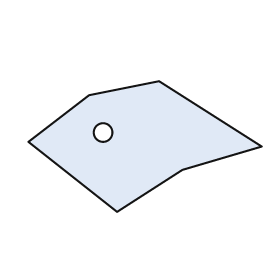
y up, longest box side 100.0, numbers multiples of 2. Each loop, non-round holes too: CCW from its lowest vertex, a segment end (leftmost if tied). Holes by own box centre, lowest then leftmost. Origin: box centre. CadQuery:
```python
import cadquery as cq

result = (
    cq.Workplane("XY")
    .moveTo(-12.0, -28.0)
    .lineTo(16.0, -10.0)
    .lineTo(50.0, 0.0)
    .lineTo(6.0, 28.0)
    .lineTo(-24.0, 22.0)
    .lineTo(-50.0, 2.0)
    .close()
    .moveTo(-18.0, 6.0)
    .circle(4.0)
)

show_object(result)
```